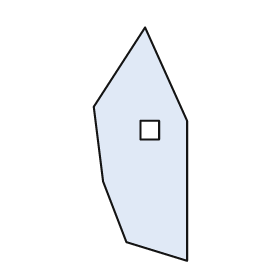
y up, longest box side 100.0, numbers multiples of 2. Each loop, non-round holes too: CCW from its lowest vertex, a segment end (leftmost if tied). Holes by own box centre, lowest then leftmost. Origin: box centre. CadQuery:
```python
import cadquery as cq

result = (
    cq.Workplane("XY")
    .moveTo(20.0, -50.0)
    .lineTo(20.0, 10.0)
    .lineTo(2.0, 50.0)
    .lineTo(-20.0, 16.0)
    .lineTo(-16.0, -16.0)
    .lineTo(-6.0, -42.0)
    .close()
    .moveTo(0.0, 2.0)
    .lineTo(8.0, 2.0)
    .lineTo(8.0, 10.0)
    .lineTo(0.0, 10.0)
    .close()
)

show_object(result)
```